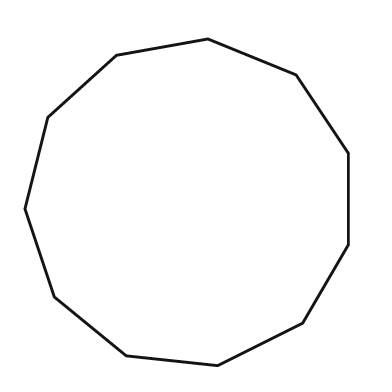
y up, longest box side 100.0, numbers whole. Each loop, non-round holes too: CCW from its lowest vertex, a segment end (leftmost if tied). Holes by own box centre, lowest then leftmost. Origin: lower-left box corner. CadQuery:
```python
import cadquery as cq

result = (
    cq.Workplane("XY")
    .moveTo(59.0, 0.0)
    .lineTo(85.0, 13.0)
    .lineTo(99.0, 37.0)
    .lineTo(99.0, 65.0)
    .lineTo(83.0, 89.0)
    .lineTo(56.0, 100.0)
    .lineTo(28.0, 95.0)
    .lineTo(7.0, 76.0)
    .lineTo(0.0, 48.0)
    .lineTo(9.0, 21.0)
    .lineTo(31.0, 3.0)
    .close()
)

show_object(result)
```